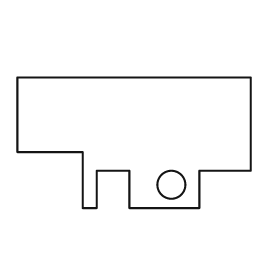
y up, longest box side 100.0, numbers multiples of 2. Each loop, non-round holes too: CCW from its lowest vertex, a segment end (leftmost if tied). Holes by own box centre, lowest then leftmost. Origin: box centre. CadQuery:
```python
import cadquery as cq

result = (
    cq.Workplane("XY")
    .moveTo(-22.0, -28.0)
    .lineTo(-16.0, -28.0)
    .lineTo(-16.0, -12.0)
    .lineTo(-2.0, -12.0)
    .lineTo(-2.0, -28.0)
    .lineTo(28.0, -28.0)
    .lineTo(28.0, -12.0)
    .lineTo(50.0, -12.0)
    .lineTo(50.0, 28.0)
    .lineTo(-50.0, 28.0)
    .lineTo(-50.0, -4.0)
    .lineTo(-22.0, -4.0)
    .close()
    .moveTo(16.0, -18.0)
    .circle(6.0)
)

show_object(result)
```